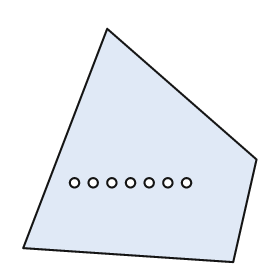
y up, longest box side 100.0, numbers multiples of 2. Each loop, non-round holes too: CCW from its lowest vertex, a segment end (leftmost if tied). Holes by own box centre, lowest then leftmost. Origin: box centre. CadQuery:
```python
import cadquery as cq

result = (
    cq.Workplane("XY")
    .moveTo(40.0, -50.0)
    .lineTo(50.0, -6.0)
    .lineTo(-14.0, 50.0)
    .lineTo(-50.0, -44.0)
    .close()
    .moveTo(-28.0, -16.0)
    .circle(2.0)
    .moveTo(-20.0, -16.0)
    .circle(2.0)
    .moveTo(-12.0, -16.0)
    .circle(2.0)
    .moveTo(-4.0, -16.0)
    .circle(2.0)
    .moveTo(4.0, -16.0)
    .circle(2.0)
    .moveTo(12.0, -16.0)
    .circle(2.0)
    .moveTo(20.0, -16.0)
    .circle(2.0)
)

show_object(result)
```